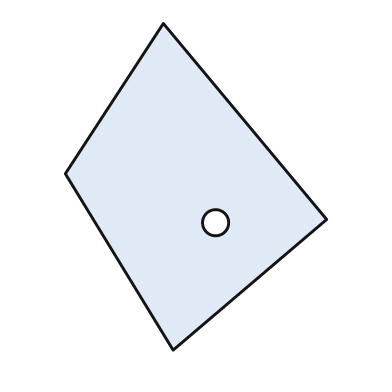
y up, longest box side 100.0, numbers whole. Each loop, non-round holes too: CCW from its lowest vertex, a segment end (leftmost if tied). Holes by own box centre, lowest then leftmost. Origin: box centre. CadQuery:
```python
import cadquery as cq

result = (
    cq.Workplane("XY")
    .moveTo(-7.0, -50.0)
    .lineTo(40.0, -10.0)
    .lineTo(-10.0, 50.0)
    .lineTo(-40.0, 4.0)
    .close()
    .moveTo(6.0, -11.0)
    .circle(4.0)
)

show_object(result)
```